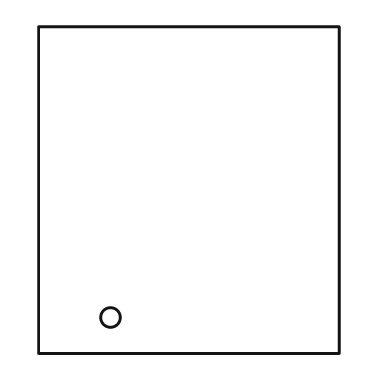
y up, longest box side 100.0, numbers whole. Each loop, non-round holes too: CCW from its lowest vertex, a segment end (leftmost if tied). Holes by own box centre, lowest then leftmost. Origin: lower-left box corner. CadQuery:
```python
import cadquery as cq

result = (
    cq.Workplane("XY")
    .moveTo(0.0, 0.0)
    .lineTo(92.0, 0.0)
    .lineTo(92.0, 100.0)
    .lineTo(0.0, 100.0)
    .close()
    .moveTo(22.0, 11.0)
    .circle(3.0)
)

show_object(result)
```